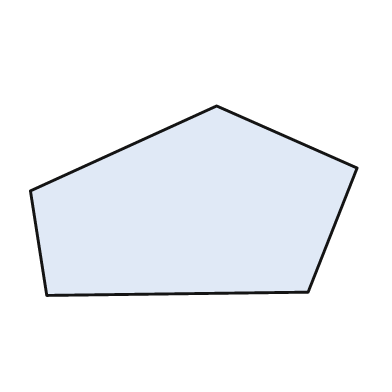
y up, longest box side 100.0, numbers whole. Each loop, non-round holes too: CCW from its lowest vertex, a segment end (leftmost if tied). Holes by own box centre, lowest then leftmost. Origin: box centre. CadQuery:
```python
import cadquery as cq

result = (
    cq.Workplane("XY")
    .moveTo(-45.0, -29.0)
    .lineTo(35.0, -28.0)
    .lineTo(50.0, 10.0)
    .lineTo(7.0, 29.0)
    .lineTo(-50.0, 3.0)
    .close()
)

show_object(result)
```